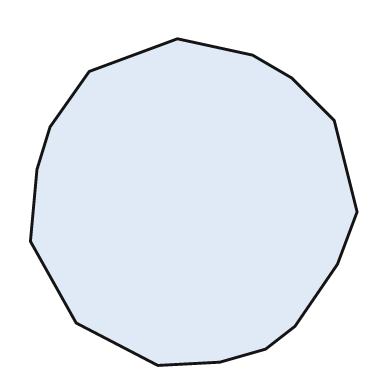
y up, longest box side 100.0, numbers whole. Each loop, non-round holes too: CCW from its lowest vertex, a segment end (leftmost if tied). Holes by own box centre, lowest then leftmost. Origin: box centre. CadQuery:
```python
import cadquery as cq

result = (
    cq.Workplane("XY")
    .moveTo(-11.0, -50.0)
    .lineTo(8.0, -49.0)
    .lineTo(22.0, -45.0)
    .lineTo(31.0, -38.0)
    .lineTo(44.0, -19.0)
    .lineTo(50.0, -3.0)
    .lineTo(43.0, 25.0)
    .lineTo(30.0, 38.0)
    .lineTo(18.0, 45.0)
    .lineTo(-5.0, 50.0)
    .lineTo(-32.0, 40.0)
    .lineTo(-44.0, 23.0)
    .lineTo(-48.0, 10.0)
    .lineTo(-50.0, -12.0)
    .lineTo(-36.0, -37.0)
    .close()
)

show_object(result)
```